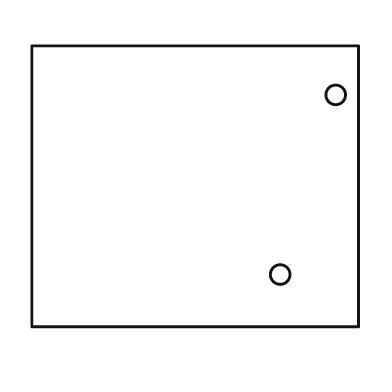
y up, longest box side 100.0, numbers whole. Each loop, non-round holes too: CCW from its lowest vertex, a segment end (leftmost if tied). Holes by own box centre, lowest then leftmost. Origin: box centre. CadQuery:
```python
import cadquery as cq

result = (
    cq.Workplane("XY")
    .moveTo(-50.0, -43.0)
    .lineTo(50.0, -43.0)
    .lineTo(50.0, 43.0)
    .lineTo(-50.0, 43.0)
    .close()
    .moveTo(26.0, -27.0)
    .circle(3.0)
    .moveTo(43.0, 28.0)
    .circle(3.0)
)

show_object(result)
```